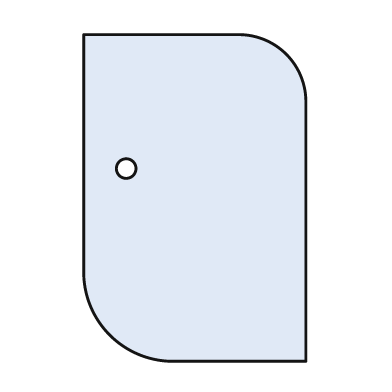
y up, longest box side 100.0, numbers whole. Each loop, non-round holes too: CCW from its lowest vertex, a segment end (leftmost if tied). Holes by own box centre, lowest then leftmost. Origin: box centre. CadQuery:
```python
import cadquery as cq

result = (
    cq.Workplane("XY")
    .moveTo(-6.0, -50.0)
    .lineTo(34.0, -50.0)
    .lineTo(34.0, 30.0)
    .threePointArc((28.0, 44.0), (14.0, 50.0))
    .lineTo(-34.0, 50.0)
    .lineTo(-34.0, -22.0)
    .threePointArc((-26.0, -42.0), (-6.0, -50.0))
    .close()
    .moveTo(-21.0, 9.0)
    .circle(3.0)
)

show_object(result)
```